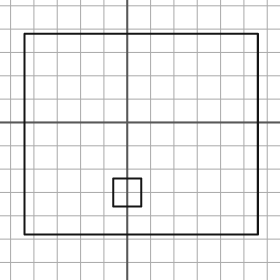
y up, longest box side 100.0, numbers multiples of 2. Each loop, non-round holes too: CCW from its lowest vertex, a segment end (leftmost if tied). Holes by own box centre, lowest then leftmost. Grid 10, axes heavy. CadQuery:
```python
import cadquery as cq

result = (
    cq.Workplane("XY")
    .moveTo(-44.0, -48.0)
    .lineTo(56.0, -48.0)
    .lineTo(56.0, 38.0)
    .lineTo(-44.0, 38.0)
    .close()
    .moveTo(-6.0, -36.0)
    .lineTo(6.0, -36.0)
    .lineTo(6.0, -24.0)
    .lineTo(-6.0, -24.0)
    .close()
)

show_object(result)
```